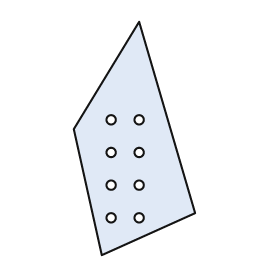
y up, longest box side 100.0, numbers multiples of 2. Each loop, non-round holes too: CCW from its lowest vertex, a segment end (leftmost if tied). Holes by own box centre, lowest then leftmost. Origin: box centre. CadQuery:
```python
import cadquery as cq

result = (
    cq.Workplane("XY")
    .moveTo(-14.0, -50.0)
    .lineTo(26.0, -32.0)
    .lineTo(2.0, 50.0)
    .lineTo(-26.0, 4.0)
    .close()
    .moveTo(-10.0, -34.0)
    .circle(2.0)
    .moveTo(2.0, -34.0)
    .circle(2.0)
    .moveTo(-10.0, -20.0)
    .circle(2.0)
    .moveTo(2.0, -20.0)
    .circle(2.0)
    .moveTo(-10.0, -6.0)
    .circle(2.0)
    .moveTo(2.0, -6.0)
    .circle(2.0)
    .moveTo(-10.0, 8.0)
    .circle(2.0)
    .moveTo(2.0, 8.0)
    .circle(2.0)
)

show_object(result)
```